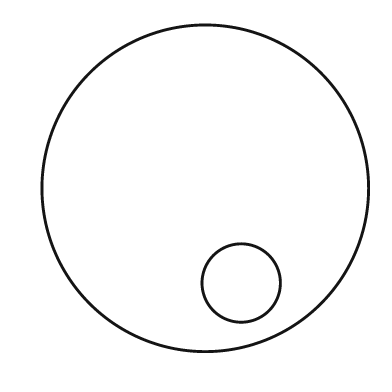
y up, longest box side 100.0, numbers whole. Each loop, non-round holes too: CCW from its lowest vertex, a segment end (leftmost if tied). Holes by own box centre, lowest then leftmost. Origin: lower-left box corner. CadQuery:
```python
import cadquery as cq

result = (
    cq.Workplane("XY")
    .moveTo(50.0, 50.0)
    .circle(50.0)
    .moveTo(61.0, 21.0)
    .circle(12.0)
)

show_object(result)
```